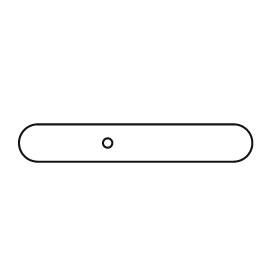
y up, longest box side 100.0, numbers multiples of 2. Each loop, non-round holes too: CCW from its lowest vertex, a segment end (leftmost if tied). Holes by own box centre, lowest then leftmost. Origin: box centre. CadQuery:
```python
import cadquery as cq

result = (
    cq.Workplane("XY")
    .moveTo(-42.0, -8.0)
    .lineTo(42.0, -8.0)
    .threePointArc((50.0, 0.0), (42.0, 8.0))
    .lineTo(-42.0, 8.0)
    .threePointArc((-50.0, 0.0), (-42.0, -8.0))
    .close()
    .moveTo(-12.0, 0.0)
    .circle(2.0)
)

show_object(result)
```